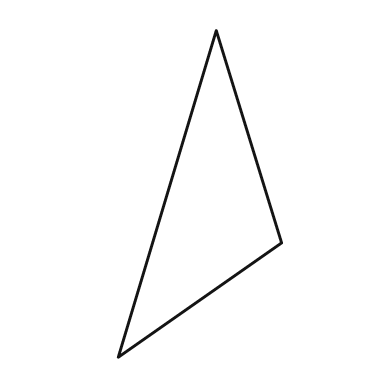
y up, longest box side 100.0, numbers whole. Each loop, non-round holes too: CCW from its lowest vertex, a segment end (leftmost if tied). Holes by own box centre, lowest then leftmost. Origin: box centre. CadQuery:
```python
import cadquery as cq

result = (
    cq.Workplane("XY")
    .moveTo(-25.0, -50.0)
    .lineTo(25.0, -15.0)
    .lineTo(5.0, 50.0)
    .close()
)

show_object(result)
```